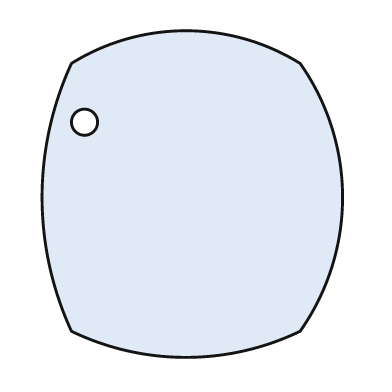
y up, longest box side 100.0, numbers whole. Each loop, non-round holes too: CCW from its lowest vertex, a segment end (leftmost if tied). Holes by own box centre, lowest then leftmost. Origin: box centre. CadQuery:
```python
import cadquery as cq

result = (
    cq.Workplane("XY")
    .moveTo(-37.0, -42.0)
    .threePointArc((-2.0, -50.0), (33.0, -42.0))
    .threePointArc((46.0, -1.0), (33.0, 40.0))
    .threePointArc((-2.0, 50.0), (-37.0, 40.0))
    .threePointArc((-46.0, -1.0), (-37.0, -42.0))
    .close()
    .moveTo(-33.0, 22.0)
    .circle(4.0)
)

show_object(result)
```